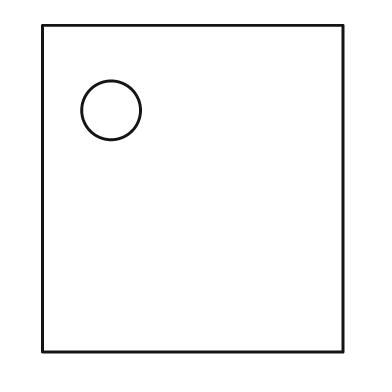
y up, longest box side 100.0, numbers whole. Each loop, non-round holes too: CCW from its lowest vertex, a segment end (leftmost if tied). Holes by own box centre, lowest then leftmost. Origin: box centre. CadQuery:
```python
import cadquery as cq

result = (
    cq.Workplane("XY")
    .moveTo(-46.0, -50.0)
    .lineTo(46.0, -50.0)
    .lineTo(46.0, 50.0)
    .lineTo(-46.0, 50.0)
    .close()
    .moveTo(-25.0, 24.0)
    .circle(9.0)
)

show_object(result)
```